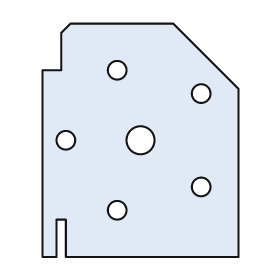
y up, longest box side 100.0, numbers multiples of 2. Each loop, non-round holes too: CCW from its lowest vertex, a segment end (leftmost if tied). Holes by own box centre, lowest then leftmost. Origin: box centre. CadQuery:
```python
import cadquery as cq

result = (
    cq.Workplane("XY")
    .moveTo(-42.0, -50.0)
    .lineTo(-36.0, -50.0)
    .lineTo(-36.0, -34.0)
    .lineTo(-32.0, -34.0)
    .lineTo(-32.0, -50.0)
    .lineTo(42.0, -50.0)
    .lineTo(42.0, 22.0)
    .lineTo(14.0, 50.0)
    .lineTo(-30.0, 50.0)
    .lineTo(-34.0, 46.0)
    .lineTo(-34.0, 30.0)
    .lineTo(-42.0, 30.0)
    .close()
    .moveTo(-10.0, -30.0)
    .circle(4.0)
    .moveTo(26.0, -20.0)
    .circle(4.0)
    .moveTo(-32.0, 0.0)
    .circle(4.0)
    .moveTo(0.0, 0.0)
    .circle(6.0)
    .moveTo(26.0, 20.0)
    .circle(4.0)
    .moveTo(-10.0, 30.0)
    .circle(4.0)
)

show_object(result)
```